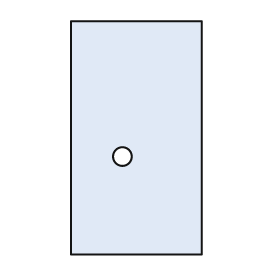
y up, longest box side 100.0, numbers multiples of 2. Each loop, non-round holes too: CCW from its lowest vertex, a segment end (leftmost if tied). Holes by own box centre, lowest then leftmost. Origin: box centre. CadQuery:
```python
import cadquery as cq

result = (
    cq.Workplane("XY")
    .moveTo(-28.0, -50.0)
    .lineTo(28.0, -50.0)
    .lineTo(28.0, 50.0)
    .lineTo(-28.0, 50.0)
    .close()
    .moveTo(-6.0, -8.0)
    .circle(4.0)
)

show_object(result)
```